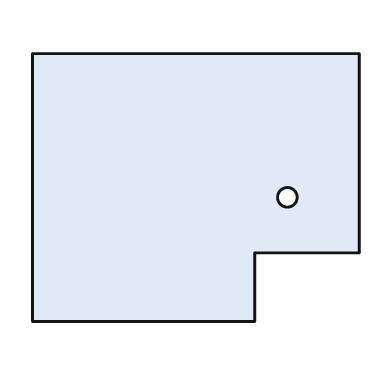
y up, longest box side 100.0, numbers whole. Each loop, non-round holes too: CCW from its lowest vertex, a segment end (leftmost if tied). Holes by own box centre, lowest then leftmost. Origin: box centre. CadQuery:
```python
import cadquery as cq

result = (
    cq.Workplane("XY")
    .moveTo(-50.0, -41.0)
    .lineTo(18.0, -41.0)
    .lineTo(18.0, -20.0)
    .lineTo(50.0, -20.0)
    .lineTo(50.0, 41.0)
    .lineTo(-50.0, 41.0)
    .close()
    .moveTo(28.0, -3.0)
    .circle(3.0)
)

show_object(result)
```